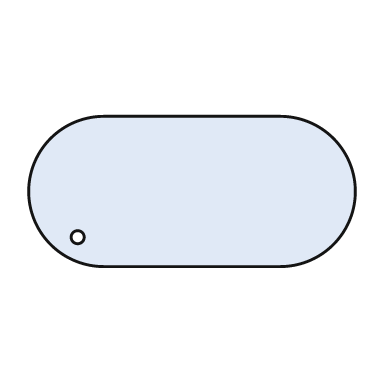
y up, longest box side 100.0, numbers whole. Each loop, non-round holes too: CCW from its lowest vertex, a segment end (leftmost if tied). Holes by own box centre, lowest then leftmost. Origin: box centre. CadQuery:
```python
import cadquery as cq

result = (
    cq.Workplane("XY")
    .moveTo(-27.0, -23.0)
    .lineTo(27.0, -23.0)
    .threePointArc((50.0, 0.0), (27.0, 23.0))
    .lineTo(-27.0, 23.0)
    .threePointArc((-50.0, 0.0), (-27.0, -23.0))
    .close()
    .moveTo(-35.0, -14.0)
    .circle(2.0)
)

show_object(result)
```